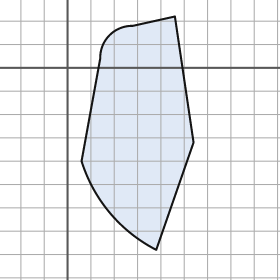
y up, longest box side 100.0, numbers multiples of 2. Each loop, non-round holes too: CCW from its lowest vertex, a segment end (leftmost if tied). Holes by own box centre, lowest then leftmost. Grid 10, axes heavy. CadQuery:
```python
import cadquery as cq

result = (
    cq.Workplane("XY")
    .moveTo(38.0, -78.0)
    .lineTo(54.0, -32.0)
    .lineTo(46.0, 22.0)
    .lineTo(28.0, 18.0)
    .threePointArc((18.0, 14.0), (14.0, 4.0))
    .lineTo(6.0, -40.0)
    .threePointArc((18.0, -62.0), (38.0, -78.0))
    .close()
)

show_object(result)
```